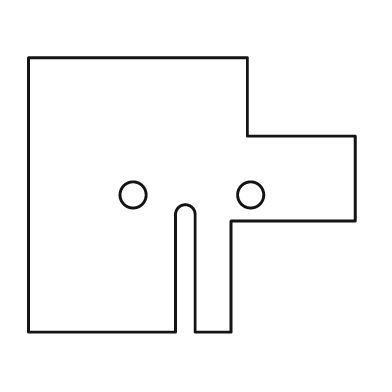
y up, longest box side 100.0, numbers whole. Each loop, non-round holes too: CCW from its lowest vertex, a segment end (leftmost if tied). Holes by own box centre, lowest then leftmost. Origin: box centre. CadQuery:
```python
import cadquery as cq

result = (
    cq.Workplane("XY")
    .moveTo(-50.0, -42.0)
    .lineTo(-5.0, -42.0)
    .lineTo(-5.0, -6.0)
    .threePointArc((-2.0, -3.0), (1.0, -6.0))
    .lineTo(1.0, -42.0)
    .lineTo(12.0, -42.0)
    .lineTo(12.0, -8.0)
    .lineTo(50.0, -8.0)
    .lineTo(50.0, 18.0)
    .lineTo(17.0, 18.0)
    .lineTo(17.0, 42.0)
    .lineTo(-50.0, 42.0)
    .close()
    .moveTo(-18.0, 0.0)
    .circle(4.0)
    .moveTo(18.0, 0.0)
    .circle(4.0)
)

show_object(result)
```